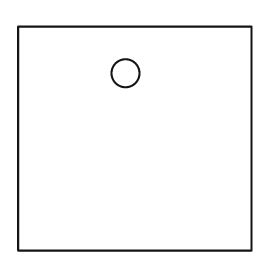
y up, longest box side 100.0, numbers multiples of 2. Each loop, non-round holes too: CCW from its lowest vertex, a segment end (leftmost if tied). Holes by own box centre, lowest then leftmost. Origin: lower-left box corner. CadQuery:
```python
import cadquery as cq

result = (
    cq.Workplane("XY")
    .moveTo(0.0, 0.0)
    .lineTo(100.0, 0.0)
    .lineTo(100.0, 96.0)
    .lineTo(0.0, 96.0)
    .close()
    .moveTo(46.0, 76.0)
    .circle(6.0)
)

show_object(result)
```